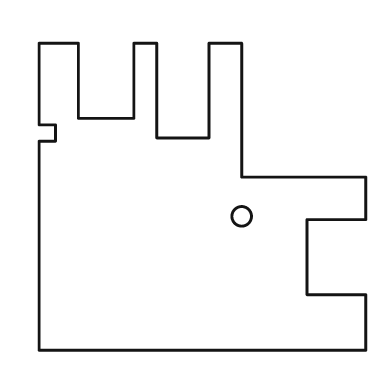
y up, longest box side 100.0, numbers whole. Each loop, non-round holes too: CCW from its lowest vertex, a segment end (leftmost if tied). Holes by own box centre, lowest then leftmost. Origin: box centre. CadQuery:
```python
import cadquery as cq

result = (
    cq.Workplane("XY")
    .moveTo(-50.0, -47.0)
    .lineTo(50.0, -47.0)
    .lineTo(50.0, -30.0)
    .lineTo(32.0, -30.0)
    .lineTo(32.0, -7.0)
    .lineTo(50.0, -7.0)
    .lineTo(50.0, 6.0)
    .lineTo(12.0, 6.0)
    .lineTo(12.0, 47.0)
    .lineTo(2.0, 47.0)
    .lineTo(2.0, 18.0)
    .lineTo(-14.0, 18.0)
    .lineTo(-14.0, 47.0)
    .lineTo(-21.0, 47.0)
    .lineTo(-21.0, 24.0)
    .lineTo(-38.0, 24.0)
    .lineTo(-38.0, 47.0)
    .lineTo(-50.0, 47.0)
    .lineTo(-50.0, 22.0)
    .lineTo(-45.0, 22.0)
    .lineTo(-45.0, 17.0)
    .lineTo(-50.0, 17.0)
    .close()
    .moveTo(12.0, -6.0)
    .circle(3.0)
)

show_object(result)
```